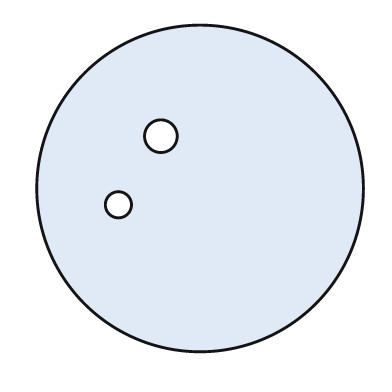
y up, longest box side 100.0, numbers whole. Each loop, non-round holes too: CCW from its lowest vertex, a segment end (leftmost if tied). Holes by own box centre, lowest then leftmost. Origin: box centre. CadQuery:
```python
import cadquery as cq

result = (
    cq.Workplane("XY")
    .moveTo(0.0, 0.0)
    .circle(50.0)
    .moveTo(-25.0, -5.0)
    .circle(4.0)
    .moveTo(-12.0, 16.0)
    .circle(5.0)
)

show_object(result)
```